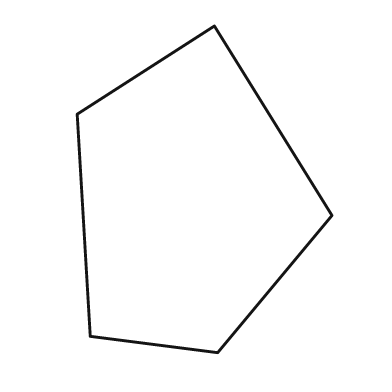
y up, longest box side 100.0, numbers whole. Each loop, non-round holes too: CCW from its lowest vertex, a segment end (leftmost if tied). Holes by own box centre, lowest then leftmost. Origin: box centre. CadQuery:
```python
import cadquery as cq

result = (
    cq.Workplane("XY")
    .moveTo(4.0, -50.0)
    .lineTo(39.0, -8.0)
    .lineTo(3.0, 50.0)
    .lineTo(-39.0, 23.0)
    .lineTo(-35.0, -45.0)
    .close()
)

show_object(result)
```